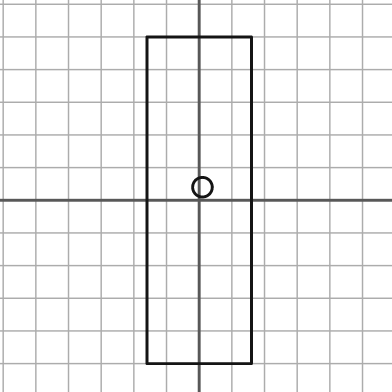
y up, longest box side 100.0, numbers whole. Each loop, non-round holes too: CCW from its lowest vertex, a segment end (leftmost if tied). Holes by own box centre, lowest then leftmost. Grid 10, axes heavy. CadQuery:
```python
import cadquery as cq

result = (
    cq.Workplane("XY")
    .moveTo(-16.0, -50.0)
    .lineTo(16.0, -50.0)
    .lineTo(16.0, 50.0)
    .lineTo(-16.0, 50.0)
    .close()
    .moveTo(1.0, 4.0)
    .circle(3.0)
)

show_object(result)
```